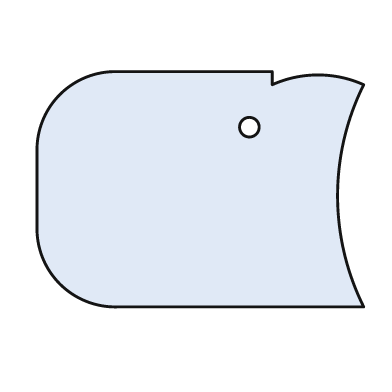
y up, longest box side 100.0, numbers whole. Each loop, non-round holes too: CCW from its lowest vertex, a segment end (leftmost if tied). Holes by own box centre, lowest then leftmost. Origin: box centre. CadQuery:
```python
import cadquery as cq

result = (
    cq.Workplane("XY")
    .moveTo(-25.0, -36.0)
    .lineTo(50.0, -36.0)
    .threePointArc((42.0, -2.0), (50.0, 32.0))
    .threePointArc((36.0, 35.0), (22.0, 32.0))
    .lineTo(22.0, 36.0)
    .lineTo(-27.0, 36.0)
    .threePointArc((-43.0, 29.0), (-50.0, 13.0))
    .lineTo(-50.0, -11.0)
    .threePointArc((-43.0, -29.0), (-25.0, -36.0))
    .close()
    .moveTo(15.0, 19.0)
    .circle(3.0)
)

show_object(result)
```